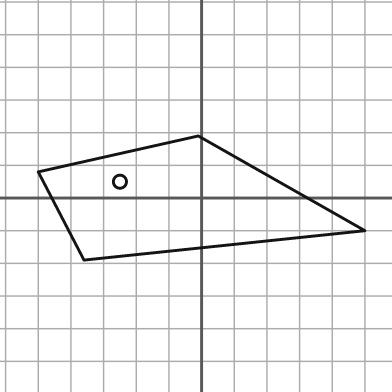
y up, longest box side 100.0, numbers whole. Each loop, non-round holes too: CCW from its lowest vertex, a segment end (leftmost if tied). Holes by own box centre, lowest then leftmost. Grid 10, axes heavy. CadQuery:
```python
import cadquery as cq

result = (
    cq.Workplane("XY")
    .moveTo(-36.0, -19.0)
    .lineTo(50.0, -10.0)
    .lineTo(-1.0, 19.0)
    .lineTo(-50.0, 8.0)
    .close()
    .moveTo(-25.0, 5.0)
    .circle(2.0)
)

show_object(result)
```